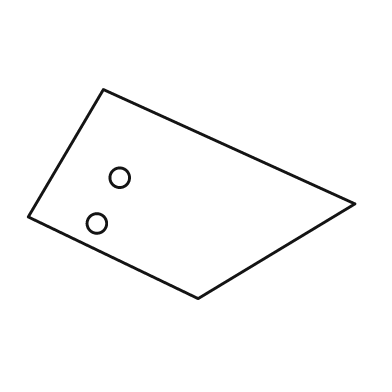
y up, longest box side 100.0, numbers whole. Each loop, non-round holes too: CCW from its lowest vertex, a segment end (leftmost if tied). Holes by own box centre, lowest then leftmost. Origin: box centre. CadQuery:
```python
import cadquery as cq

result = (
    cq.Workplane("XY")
    .moveTo(2.0, -32.0)
    .lineTo(50.0, -3.0)
    .lineTo(-27.0, 32.0)
    .lineTo(-50.0, -7.0)
    .close()
    .moveTo(-29.0, -9.0)
    .circle(3.0)
    .moveTo(-22.0, 5.0)
    .circle(3.0)
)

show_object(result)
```